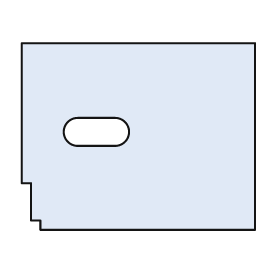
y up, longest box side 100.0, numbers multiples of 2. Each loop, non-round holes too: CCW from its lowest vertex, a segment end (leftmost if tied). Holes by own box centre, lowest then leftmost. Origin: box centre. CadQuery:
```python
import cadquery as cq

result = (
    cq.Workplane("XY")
    .moveTo(-42.0, -40.0)
    .lineTo(50.0, -40.0)
    .lineTo(50.0, 40.0)
    .lineTo(-50.0, 40.0)
    .lineTo(-50.0, -20.0)
    .lineTo(-46.0, -20.0)
    .lineTo(-46.0, -36.0)
    .lineTo(-42.0, -36.0)
    .close()
    .moveTo(-26.0, -4.0)
    .lineTo(-10.0, -4.0)
    .threePointArc((-4.0, 2.0), (-10.0, 8.0))
    .lineTo(-26.0, 8.0)
    .threePointArc((-32.0, 2.0), (-26.0, -4.0))
    .close()
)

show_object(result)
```